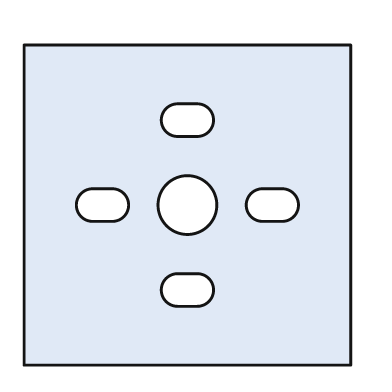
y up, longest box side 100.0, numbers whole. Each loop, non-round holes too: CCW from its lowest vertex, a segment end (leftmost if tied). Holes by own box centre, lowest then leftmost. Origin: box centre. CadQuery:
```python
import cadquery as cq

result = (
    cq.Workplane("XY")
    .moveTo(-50.0, -49.0)
    .lineTo(50.0, -49.0)
    .lineTo(50.0, 49.0)
    .lineTo(-50.0, 49.0)
    .close()
    .moveTo(-3.0, -31.0)
    .lineTo(3.0, -31.0)
    .threePointArc((8.0, -26.0), (3.0, -21.0))
    .lineTo(-3.0, -21.0)
    .threePointArc((-8.0, -26.0), (-3.0, -31.0))
    .close()
    .moveTo(-29.0, -5.0)
    .lineTo(-23.0, -5.0)
    .threePointArc((-18.0, 0.0), (-23.0, 5.0))
    .lineTo(-29.0, 5.0)
    .threePointArc((-34.0, 0.0), (-29.0, -5.0))
    .close()
    .moveTo(0.0, 0.0)
    .circle(9.0)
    .moveTo(23.0, -5.0)
    .lineTo(29.0, -5.0)
    .threePointArc((34.0, 0.0), (29.0, 5.0))
    .lineTo(23.0, 5.0)
    .threePointArc((18.0, 0.0), (23.0, -5.0))
    .close()
    .moveTo(-3.0, 21.0)
    .lineTo(3.0, 21.0)
    .threePointArc((8.0, 26.0), (3.0, 31.0))
    .lineTo(-3.0, 31.0)
    .threePointArc((-8.0, 26.0), (-3.0, 21.0))
    .close()
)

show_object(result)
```